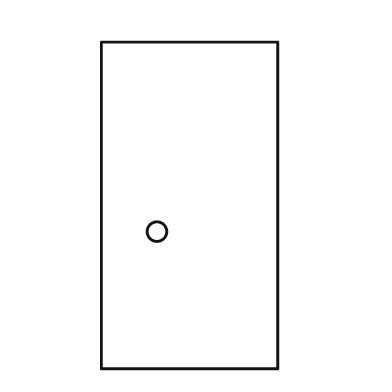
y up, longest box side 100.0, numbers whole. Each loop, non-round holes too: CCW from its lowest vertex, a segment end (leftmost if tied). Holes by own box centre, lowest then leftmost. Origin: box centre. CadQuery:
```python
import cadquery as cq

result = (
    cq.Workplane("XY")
    .moveTo(-27.0, -50.0)
    .lineTo(27.0, -50.0)
    .lineTo(27.0, 50.0)
    .lineTo(-27.0, 50.0)
    .close()
    .moveTo(-10.0, -8.0)
    .circle(3.0)
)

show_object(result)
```